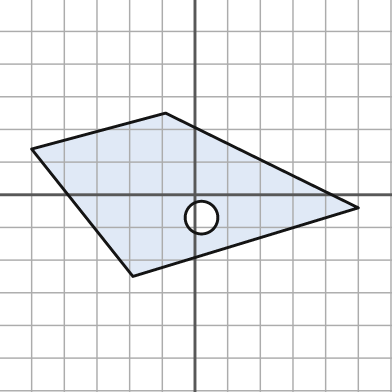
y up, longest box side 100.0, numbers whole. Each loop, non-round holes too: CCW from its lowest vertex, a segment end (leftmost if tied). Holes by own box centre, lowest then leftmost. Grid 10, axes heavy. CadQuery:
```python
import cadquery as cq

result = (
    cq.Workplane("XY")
    .moveTo(-19.0, -25.0)
    .lineTo(50.0, -4.0)
    .lineTo(-9.0, 25.0)
    .lineTo(-50.0, 14.0)
    .close()
    .moveTo(2.0, -7.0)
    .circle(5.0)
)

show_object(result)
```